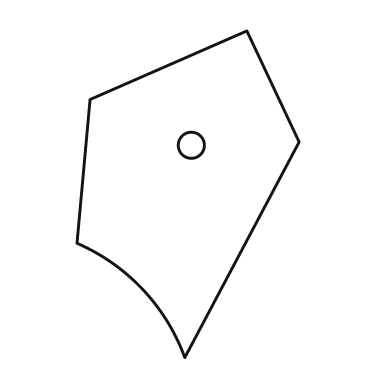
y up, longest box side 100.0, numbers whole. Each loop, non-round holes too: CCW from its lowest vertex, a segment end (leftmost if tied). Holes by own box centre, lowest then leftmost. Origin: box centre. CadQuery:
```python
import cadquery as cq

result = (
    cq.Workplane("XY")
    .moveTo(-1.0, -50.0)
    .lineTo(34.0, 16.0)
    .lineTo(18.0, 50.0)
    .lineTo(-30.0, 29.0)
    .lineTo(-34.0, -15.0)
    .threePointArc((-14.0, -29.0), (-1.0, -50.0))
    .close()
    .moveTo(1.0, 15.0)
    .circle(4.0)
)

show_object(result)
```